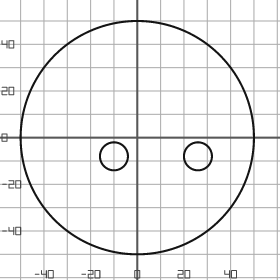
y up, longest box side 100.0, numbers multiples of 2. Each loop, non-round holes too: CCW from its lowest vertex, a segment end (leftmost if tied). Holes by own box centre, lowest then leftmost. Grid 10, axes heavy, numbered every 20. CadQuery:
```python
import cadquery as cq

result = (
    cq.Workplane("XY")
    .moveTo(0.0, 0.0)
    .circle(50.0)
    .moveTo(-10.0, -8.0)
    .circle(6.0)
    .moveTo(26.0, -8.0)
    .circle(6.0)
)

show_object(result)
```